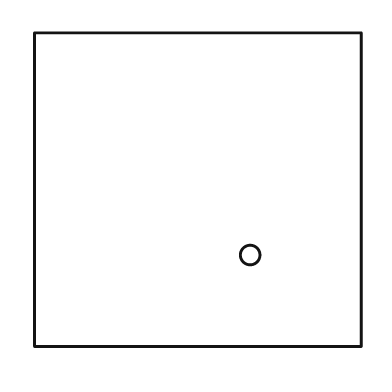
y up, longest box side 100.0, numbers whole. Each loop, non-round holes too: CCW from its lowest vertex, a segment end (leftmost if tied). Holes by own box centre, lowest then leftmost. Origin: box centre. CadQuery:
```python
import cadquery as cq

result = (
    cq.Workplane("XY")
    .moveTo(-50.0, -48.0)
    .lineTo(50.0, -48.0)
    .lineTo(50.0, 48.0)
    .lineTo(-50.0, 48.0)
    .close()
    .moveTo(16.0, -20.0)
    .circle(3.0)
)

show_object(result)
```